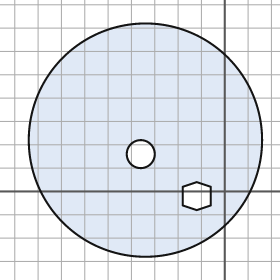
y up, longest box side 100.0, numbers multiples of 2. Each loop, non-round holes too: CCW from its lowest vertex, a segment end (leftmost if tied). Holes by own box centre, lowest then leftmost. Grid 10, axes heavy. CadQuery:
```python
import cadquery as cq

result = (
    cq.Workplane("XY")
    .moveTo(-34.0, 22.0)
    .circle(50.0)
    .moveTo(-12.0, -8.0)
    .lineTo(-6.0, -6.0)
    .lineTo(-6.0, 2.0)
    .lineTo(-12.0, 4.0)
    .lineTo(-18.0, 2.0)
    .lineTo(-18.0, -6.0)
    .close()
    .moveTo(-36.0, 16.0)
    .circle(6.0)
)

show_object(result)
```